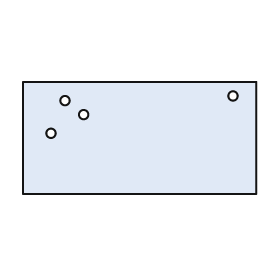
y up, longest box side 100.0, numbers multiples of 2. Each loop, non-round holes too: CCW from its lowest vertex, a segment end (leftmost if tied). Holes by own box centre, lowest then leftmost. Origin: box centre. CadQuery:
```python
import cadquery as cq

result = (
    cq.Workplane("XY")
    .moveTo(-50.0, -24.0)
    .lineTo(50.0, -24.0)
    .lineTo(50.0, 24.0)
    .lineTo(-50.0, 24.0)
    .close()
    .moveTo(-38.0, 2.0)
    .circle(2.0)
    .moveTo(-24.0, 10.0)
    .circle(2.0)
    .moveTo(-32.0, 16.0)
    .circle(2.0)
    .moveTo(40.0, 18.0)
    .circle(2.0)
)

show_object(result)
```